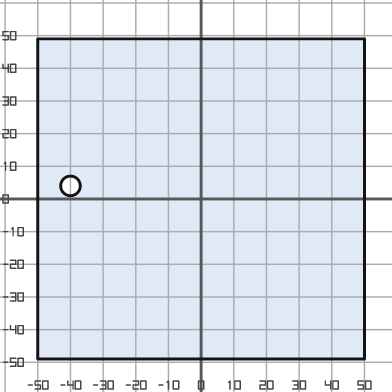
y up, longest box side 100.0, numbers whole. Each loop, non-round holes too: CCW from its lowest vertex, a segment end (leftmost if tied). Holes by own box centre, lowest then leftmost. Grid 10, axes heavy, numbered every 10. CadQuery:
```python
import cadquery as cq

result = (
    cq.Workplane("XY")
    .moveTo(-50.0, -49.0)
    .lineTo(50.0, -49.0)
    .lineTo(50.0, 49.0)
    .lineTo(-50.0, 49.0)
    .close()
    .moveTo(-40.0, 4.0)
    .circle(3.0)
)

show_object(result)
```